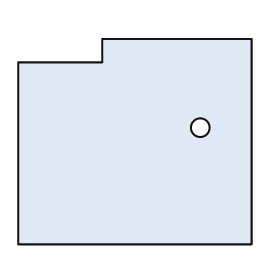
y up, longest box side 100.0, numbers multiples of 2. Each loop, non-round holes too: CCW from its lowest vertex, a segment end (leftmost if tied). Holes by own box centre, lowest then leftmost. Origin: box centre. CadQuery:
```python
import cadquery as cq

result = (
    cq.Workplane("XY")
    .moveTo(-50.0, -44.0)
    .lineTo(50.0, -44.0)
    .lineTo(50.0, 44.0)
    .lineTo(-14.0, 44.0)
    .lineTo(-14.0, 34.0)
    .lineTo(-50.0, 34.0)
    .close()
    .moveTo(28.0, 6.0)
    .circle(4.0)
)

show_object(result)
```